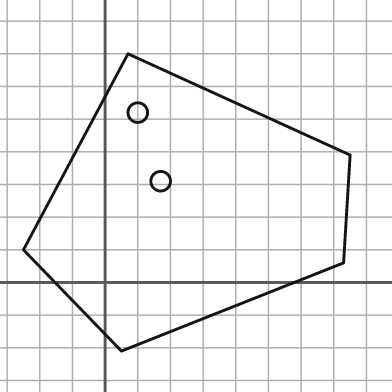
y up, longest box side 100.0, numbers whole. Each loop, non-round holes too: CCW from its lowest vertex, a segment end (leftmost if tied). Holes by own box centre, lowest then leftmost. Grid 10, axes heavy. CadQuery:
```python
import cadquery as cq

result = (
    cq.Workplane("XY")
    .moveTo(5.0, -21.0)
    .lineTo(73.0, 6.0)
    .lineTo(75.0, 39.0)
    .lineTo(7.0, 70.0)
    .lineTo(-25.0, 10.0)
    .close()
    .moveTo(17.0, 31.0)
    .circle(3.0)
    .moveTo(10.0, 52.0)
    .circle(3.0)
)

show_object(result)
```